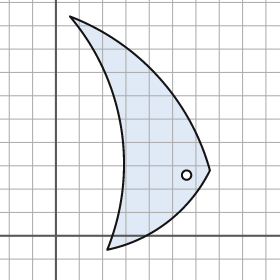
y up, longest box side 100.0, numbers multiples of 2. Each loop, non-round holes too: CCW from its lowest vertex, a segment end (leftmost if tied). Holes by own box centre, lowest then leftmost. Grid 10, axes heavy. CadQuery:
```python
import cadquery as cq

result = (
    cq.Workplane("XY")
    .moveTo(22.0, -6.0)
    .threePointArc((48.0, 6.0), (66.0, 28.0))
    .threePointArc((44.0, 68.0), (6.0, 94.0))
    .threePointArc((28.0, 46.0), (22.0, -6.0))
    .close()
    .moveTo(56.0, 26.0)
    .circle(2.0)
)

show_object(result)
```